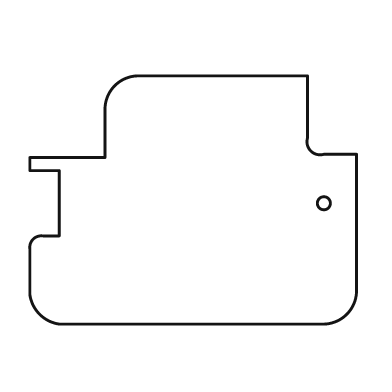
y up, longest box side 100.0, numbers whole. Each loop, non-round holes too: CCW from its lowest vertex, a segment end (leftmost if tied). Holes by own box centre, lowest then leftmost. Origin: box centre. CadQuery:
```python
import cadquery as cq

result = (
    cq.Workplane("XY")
    .moveTo(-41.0, -38.0)
    .lineTo(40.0, -38.0)
    .threePointArc((47.0, -35.0), (50.0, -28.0))
    .lineTo(50.0, 14.0)
    .lineTo(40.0, 14.0)
    .threePointArc((36.0, 15.0), (35.0, 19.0))
    .lineTo(35.0, 38.0)
    .lineTo(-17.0, 38.0)
    .threePointArc((-24.0, 35.0), (-27.0, 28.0))
    .lineTo(-27.0, 13.0)
    .lineTo(-50.0, 13.0)
    .lineTo(-50.0, 9.0)
    .lineTo(-41.0, 9.0)
    .lineTo(-41.0, -11.0)
    .lineTo(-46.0, -11.0)
    .threePointArc((-49.0, -12.0), (-50.0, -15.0))
    .lineTo(-50.0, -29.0)
    .threePointArc((-47.0, -35.0), (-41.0, -38.0))
    .close()
    .moveTo(40.0, -1.0)
    .circle(2.0)
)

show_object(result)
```